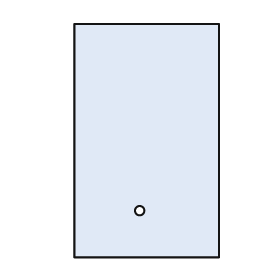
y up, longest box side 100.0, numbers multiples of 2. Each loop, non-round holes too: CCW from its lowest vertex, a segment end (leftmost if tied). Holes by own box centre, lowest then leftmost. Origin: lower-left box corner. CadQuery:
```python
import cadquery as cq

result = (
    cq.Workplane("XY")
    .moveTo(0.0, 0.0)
    .lineTo(62.0, 0.0)
    .lineTo(62.0, 100.0)
    .lineTo(0.0, 100.0)
    .close()
    .moveTo(28.0, 20.0)
    .circle(2.0)
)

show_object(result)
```